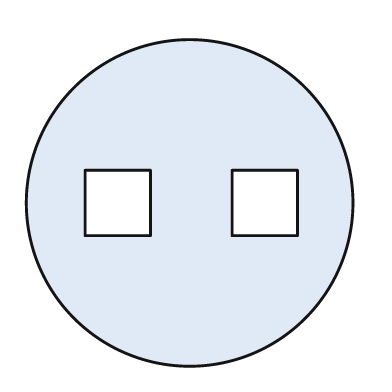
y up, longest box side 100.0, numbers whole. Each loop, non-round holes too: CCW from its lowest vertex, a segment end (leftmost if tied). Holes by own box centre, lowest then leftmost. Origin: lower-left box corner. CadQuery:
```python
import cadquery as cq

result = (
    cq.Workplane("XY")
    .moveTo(50.0, 50.0)
    .circle(50.0)
    .moveTo(18.0, 40.0)
    .lineTo(38.0, 40.0)
    .lineTo(38.0, 60.0)
    .lineTo(18.0, 60.0)
    .close()
    .moveTo(63.0, 40.0)
    .lineTo(83.0, 40.0)
    .lineTo(83.0, 60.0)
    .lineTo(63.0, 60.0)
    .close()
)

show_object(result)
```